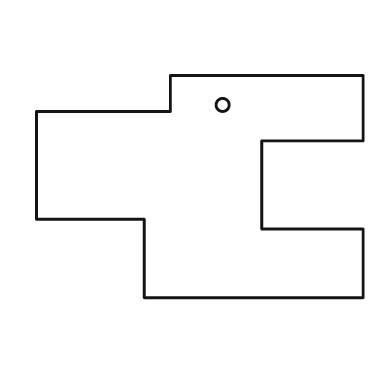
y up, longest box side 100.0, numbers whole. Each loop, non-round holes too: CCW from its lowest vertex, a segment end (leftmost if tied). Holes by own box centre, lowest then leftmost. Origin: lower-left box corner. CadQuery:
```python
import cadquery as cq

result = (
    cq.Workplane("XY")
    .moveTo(33.0, 0.0)
    .lineTo(100.0, 0.0)
    .lineTo(100.0, 21.0)
    .lineTo(69.0, 21.0)
    .lineTo(69.0, 48.0)
    .lineTo(100.0, 48.0)
    .lineTo(100.0, 68.0)
    .lineTo(41.0, 68.0)
    .lineTo(41.0, 57.0)
    .lineTo(0.0, 57.0)
    .lineTo(0.0, 24.0)
    .lineTo(33.0, 24.0)
    .close()
    .moveTo(57.0, 59.0)
    .circle(2.0)
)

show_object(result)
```